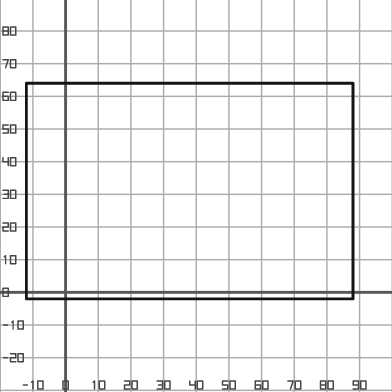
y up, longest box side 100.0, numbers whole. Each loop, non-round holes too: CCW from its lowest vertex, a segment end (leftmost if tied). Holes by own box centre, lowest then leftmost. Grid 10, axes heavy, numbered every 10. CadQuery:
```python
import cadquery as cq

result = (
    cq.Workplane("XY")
    .moveTo(-12.0, -2.0)
    .lineTo(88.0, -2.0)
    .lineTo(88.0, 64.0)
    .lineTo(-12.0, 64.0)
    .close()
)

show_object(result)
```